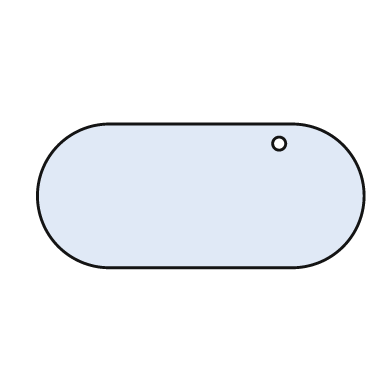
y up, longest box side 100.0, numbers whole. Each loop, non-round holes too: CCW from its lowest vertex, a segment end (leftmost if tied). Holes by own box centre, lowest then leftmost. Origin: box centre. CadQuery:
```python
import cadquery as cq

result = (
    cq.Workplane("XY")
    .moveTo(-28.0, -22.0)
    .lineTo(28.0, -22.0)
    .threePointArc((50.0, 0.0), (28.0, 22.0))
    .lineTo(-28.0, 22.0)
    .threePointArc((-50.0, 0.0), (-28.0, -22.0))
    .close()
    .moveTo(24.0, 16.0)
    .circle(2.0)
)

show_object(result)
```